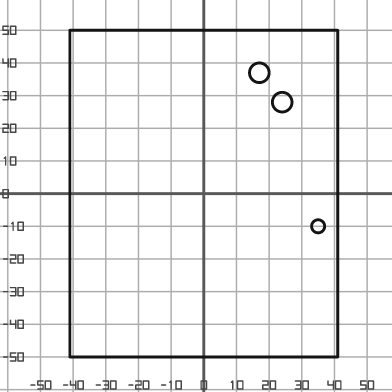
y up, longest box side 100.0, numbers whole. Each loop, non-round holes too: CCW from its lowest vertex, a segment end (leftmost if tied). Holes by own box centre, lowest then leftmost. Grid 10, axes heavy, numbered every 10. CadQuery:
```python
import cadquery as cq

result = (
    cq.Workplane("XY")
    .moveTo(-41.0, -50.0)
    .lineTo(41.0, -50.0)
    .lineTo(41.0, 50.0)
    .lineTo(-41.0, 50.0)
    .close()
    .moveTo(35.0, -10.0)
    .circle(2.0)
    .moveTo(24.0, 28.0)
    .circle(3.0)
    .moveTo(17.0, 37.0)
    .circle(3.0)
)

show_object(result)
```